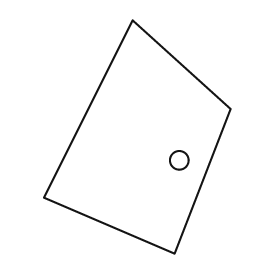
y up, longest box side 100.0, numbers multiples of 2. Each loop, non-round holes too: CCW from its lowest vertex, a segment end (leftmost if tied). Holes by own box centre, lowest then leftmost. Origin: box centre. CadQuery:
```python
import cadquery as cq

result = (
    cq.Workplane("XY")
    .moveTo(16.0, -50.0)
    .lineTo(40.0, 12.0)
    .lineTo(-2.0, 50.0)
    .lineTo(-40.0, -26.0)
    .close()
    .moveTo(18.0, -10.0)
    .circle(4.0)
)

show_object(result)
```